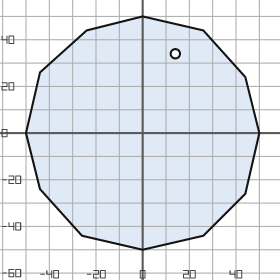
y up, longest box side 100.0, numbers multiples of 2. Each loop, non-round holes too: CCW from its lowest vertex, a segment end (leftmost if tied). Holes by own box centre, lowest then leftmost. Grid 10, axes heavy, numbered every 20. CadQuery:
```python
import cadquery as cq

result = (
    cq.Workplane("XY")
    .moveTo(0.0, -50.0)
    .lineTo(26.0, -44.0)
    .lineTo(44.0, -26.0)
    .lineTo(50.0, 0.0)
    .lineTo(44.0, 24.0)
    .lineTo(26.0, 44.0)
    .lineTo(0.0, 50.0)
    .lineTo(-24.0, 44.0)
    .lineTo(-44.0, 26.0)
    .lineTo(-50.0, 0.0)
    .lineTo(-44.0, -24.0)
    .lineTo(-26.0, -44.0)
    .close()
    .moveTo(14.0, 34.0)
    .circle(2.0)
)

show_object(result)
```